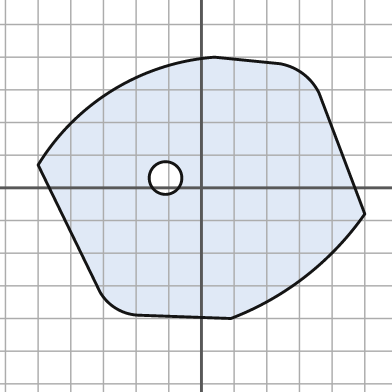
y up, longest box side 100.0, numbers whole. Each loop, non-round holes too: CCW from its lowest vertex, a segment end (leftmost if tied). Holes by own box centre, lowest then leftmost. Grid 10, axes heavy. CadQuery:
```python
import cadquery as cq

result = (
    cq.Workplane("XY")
    .moveTo(9.0, -40.0)
    .threePointArc((32.0, -27.0), (50.0, -8.0))
    .lineTo(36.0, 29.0)
    .threePointArc((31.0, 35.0), (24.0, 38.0))
    .lineTo(4.0, 40.0)
    .threePointArc((-27.0, 30.0), (-50.0, 7.0))
    .lineTo(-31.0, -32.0)
    .threePointArc((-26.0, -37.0), (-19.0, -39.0))
    .close()
    .moveTo(-11.0, 3.0)
    .circle(5.0)
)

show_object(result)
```